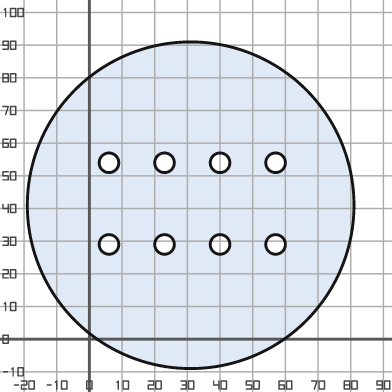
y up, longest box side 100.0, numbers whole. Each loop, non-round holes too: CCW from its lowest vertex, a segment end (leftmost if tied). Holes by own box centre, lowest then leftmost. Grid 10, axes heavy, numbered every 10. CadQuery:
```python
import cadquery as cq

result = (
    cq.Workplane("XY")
    .moveTo(31.0, 41.0)
    .circle(50.0)
    .moveTo(6.0, 29.0)
    .circle(3.0)
    .moveTo(23.0, 29.0)
    .circle(3.0)
    .moveTo(40.0, 29.0)
    .circle(3.0)
    .moveTo(57.0, 29.0)
    .circle(3.0)
    .moveTo(6.0, 54.0)
    .circle(3.0)
    .moveTo(23.0, 54.0)
    .circle(3.0)
    .moveTo(40.0, 54.0)
    .circle(3.0)
    .moveTo(57.0, 54.0)
    .circle(3.0)
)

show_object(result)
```